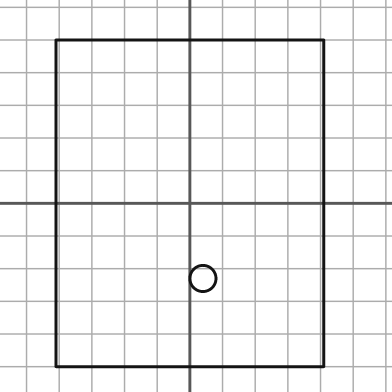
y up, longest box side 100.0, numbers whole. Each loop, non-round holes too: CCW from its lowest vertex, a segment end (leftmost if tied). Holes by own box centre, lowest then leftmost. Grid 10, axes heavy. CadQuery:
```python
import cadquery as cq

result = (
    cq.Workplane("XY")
    .moveTo(-41.0, -50.0)
    .lineTo(41.0, -50.0)
    .lineTo(41.0, 50.0)
    .lineTo(-41.0, 50.0)
    .close()
    .moveTo(4.0, -23.0)
    .circle(4.0)
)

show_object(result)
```